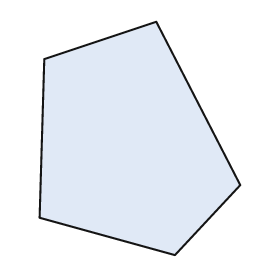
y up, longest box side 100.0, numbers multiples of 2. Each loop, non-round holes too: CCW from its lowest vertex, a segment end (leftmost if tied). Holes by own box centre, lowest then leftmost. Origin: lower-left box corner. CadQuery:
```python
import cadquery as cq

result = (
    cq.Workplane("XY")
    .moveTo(58.0, 0.0)
    .lineTo(86.0, 30.0)
    .lineTo(50.0, 100.0)
    .lineTo(2.0, 84.0)
    .lineTo(0.0, 16.0)
    .close()
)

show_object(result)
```